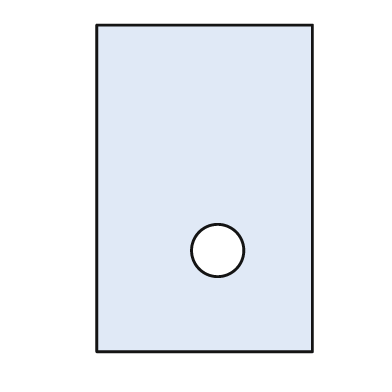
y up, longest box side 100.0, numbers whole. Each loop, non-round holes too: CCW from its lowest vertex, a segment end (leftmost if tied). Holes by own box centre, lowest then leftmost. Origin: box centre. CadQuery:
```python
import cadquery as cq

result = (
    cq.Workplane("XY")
    .moveTo(-33.0, -50.0)
    .lineTo(33.0, -50.0)
    .lineTo(33.0, 50.0)
    .lineTo(-33.0, 50.0)
    .close()
    .moveTo(4.0, -19.0)
    .circle(8.0)
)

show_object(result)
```